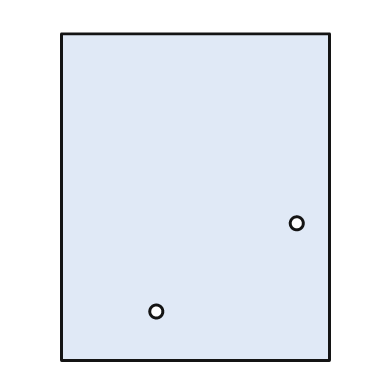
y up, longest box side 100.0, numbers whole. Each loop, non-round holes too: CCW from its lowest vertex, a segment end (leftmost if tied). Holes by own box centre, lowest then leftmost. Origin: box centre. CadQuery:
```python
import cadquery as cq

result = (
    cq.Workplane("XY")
    .moveTo(-41.0, -50.0)
    .lineTo(41.0, -50.0)
    .lineTo(41.0, 50.0)
    .lineTo(-41.0, 50.0)
    .close()
    .moveTo(-12.0, -35.0)
    .circle(2.0)
    .moveTo(31.0, -8.0)
    .circle(2.0)
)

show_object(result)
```